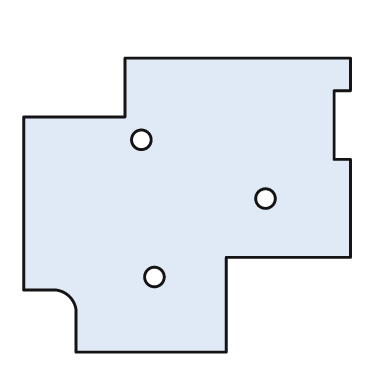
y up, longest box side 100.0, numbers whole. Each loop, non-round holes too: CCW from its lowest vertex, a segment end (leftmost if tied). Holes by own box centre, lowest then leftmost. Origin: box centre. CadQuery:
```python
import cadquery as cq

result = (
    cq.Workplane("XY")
    .moveTo(-34.0, -45.0)
    .lineTo(12.0, -45.0)
    .lineTo(12.0, -16.0)
    .lineTo(50.0, -16.0)
    .lineTo(50.0, 14.0)
    .lineTo(45.0, 14.0)
    .lineTo(45.0, 35.0)
    .lineTo(50.0, 35.0)
    .lineTo(50.0, 45.0)
    .lineTo(-19.0, 45.0)
    .lineTo(-19.0, 27.0)
    .lineTo(-50.0, 27.0)
    .lineTo(-50.0, -26.0)
    .lineTo(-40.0, -26.0)
    .threePointArc((-36.0, -28.0), (-34.0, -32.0))
    .close()
    .moveTo(-10.0, -22.0)
    .circle(3.0)
    .moveTo(24.0, 2.0)
    .circle(3.0)
    .moveTo(-14.0, 20.0)
    .circle(3.0)
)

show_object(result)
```